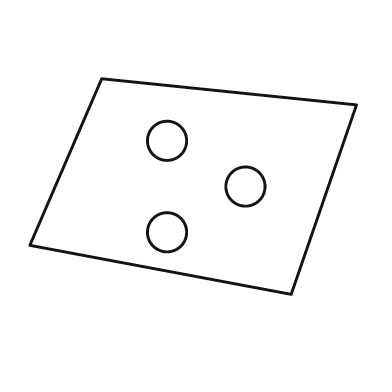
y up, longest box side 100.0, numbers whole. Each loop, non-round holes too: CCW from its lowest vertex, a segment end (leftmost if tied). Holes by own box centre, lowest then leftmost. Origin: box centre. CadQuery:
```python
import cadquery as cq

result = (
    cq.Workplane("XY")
    .moveTo(30.0, -33.0)
    .lineTo(50.0, 25.0)
    .lineTo(-28.0, 33.0)
    .lineTo(-50.0, -18.0)
    .close()
    .moveTo(-8.0, -14.0)
    .circle(6.0)
    .moveTo(16.0, 0.0)
    .circle(6.0)
    .moveTo(-8.0, 14.0)
    .circle(6.0)
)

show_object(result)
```